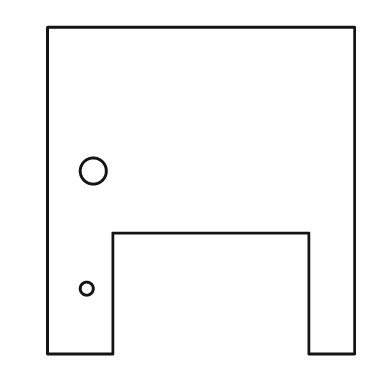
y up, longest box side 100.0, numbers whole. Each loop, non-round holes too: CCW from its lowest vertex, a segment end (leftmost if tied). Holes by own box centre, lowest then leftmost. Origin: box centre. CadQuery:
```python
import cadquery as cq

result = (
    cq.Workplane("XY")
    .moveTo(-47.0, -50.0)
    .lineTo(-27.0, -50.0)
    .lineTo(-27.0, -13.0)
    .lineTo(33.0, -13.0)
    .lineTo(33.0, -50.0)
    .lineTo(47.0, -50.0)
    .lineTo(47.0, 50.0)
    .lineTo(-47.0, 50.0)
    .close()
    .moveTo(-35.0, -30.0)
    .circle(2.0)
    .moveTo(-33.0, 6.0)
    .circle(4.0)
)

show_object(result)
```